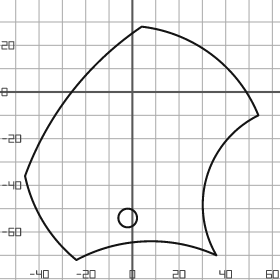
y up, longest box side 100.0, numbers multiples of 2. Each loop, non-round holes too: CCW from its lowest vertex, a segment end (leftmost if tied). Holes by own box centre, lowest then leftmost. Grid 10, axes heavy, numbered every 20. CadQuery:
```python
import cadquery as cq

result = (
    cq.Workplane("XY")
    .moveTo(-24.0, -72.0)
    .threePointArc((6.0, -64.0), (36.0, -70.0))
    .threePointArc((32.0, -36.0), (54.0, -10.0))
    .threePointArc((34.0, 16.0), (4.0, 28.0))
    .threePointArc((-26.0, 0.0), (-46.0, -36.0))
    .threePointArc((-38.0, -56.0), (-24.0, -72.0))
    .close()
    .moveTo(-2.0, -54.0)
    .circle(4.0)
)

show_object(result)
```